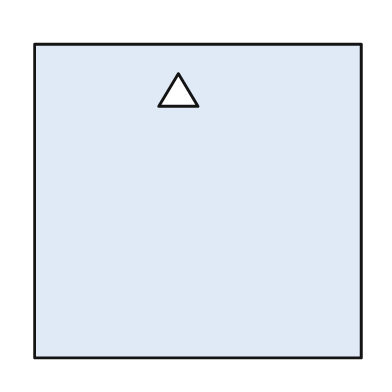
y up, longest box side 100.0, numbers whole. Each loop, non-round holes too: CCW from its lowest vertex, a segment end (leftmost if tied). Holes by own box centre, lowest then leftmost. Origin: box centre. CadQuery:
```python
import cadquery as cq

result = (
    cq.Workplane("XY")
    .moveTo(-50.0, -48.0)
    .lineTo(50.0, -48.0)
    .lineTo(50.0, 48.0)
    .lineTo(-50.0, 48.0)
    .close()
    .moveTo(-12.0, 29.0)
    .lineTo(0.0, 29.0)
    .lineTo(-6.0, 39.0)
    .close()
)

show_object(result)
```